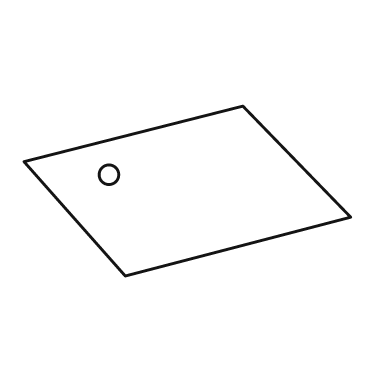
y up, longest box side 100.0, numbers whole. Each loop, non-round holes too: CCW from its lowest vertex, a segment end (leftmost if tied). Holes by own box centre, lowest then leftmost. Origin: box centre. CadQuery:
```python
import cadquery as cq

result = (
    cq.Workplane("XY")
    .moveTo(-19.0, -26.0)
    .lineTo(50.0, -8.0)
    .lineTo(17.0, 26.0)
    .lineTo(-50.0, 9.0)
    .close()
    .moveTo(-24.0, 5.0)
    .circle(3.0)
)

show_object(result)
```